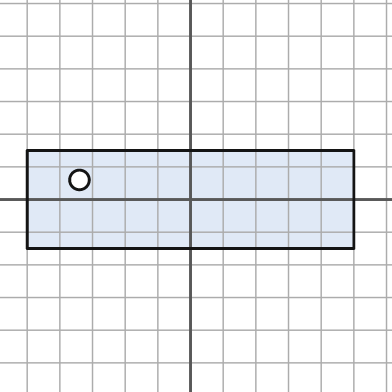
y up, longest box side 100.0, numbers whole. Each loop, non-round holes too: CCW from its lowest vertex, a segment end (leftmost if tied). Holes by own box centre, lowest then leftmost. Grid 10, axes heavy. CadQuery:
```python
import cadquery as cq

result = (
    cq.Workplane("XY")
    .moveTo(-50.0, -15.0)
    .lineTo(50.0, -15.0)
    .lineTo(50.0, 15.0)
    .lineTo(-50.0, 15.0)
    .close()
    .moveTo(-34.0, 6.0)
    .circle(3.0)
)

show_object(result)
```